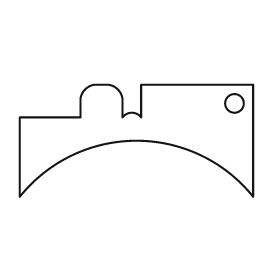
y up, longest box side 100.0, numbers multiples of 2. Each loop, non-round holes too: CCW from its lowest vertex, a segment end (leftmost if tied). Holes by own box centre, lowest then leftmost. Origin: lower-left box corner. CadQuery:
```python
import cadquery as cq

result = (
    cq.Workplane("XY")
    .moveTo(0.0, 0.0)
    .threePointArc((50.0, 24.0), (100.0, 0.0))
    .lineTo(100.0, 48.0)
    .lineTo(52.0, 48.0)
    .lineTo(52.0, 34.0)
    .threePointArc((48.0, 36.0), (44.0, 34.0))
    .lineTo(44.0, 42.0)
    .threePointArc((42.0, 46.0), (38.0, 48.0))
    .lineTo(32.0, 48.0)
    .threePointArc((28.0, 46.0), (26.0, 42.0))
    .lineTo(26.0, 34.0)
    .lineTo(0.0, 34.0)
    .close()
    .moveTo(92.0, 40.0)
    .circle(4.0)
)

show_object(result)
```